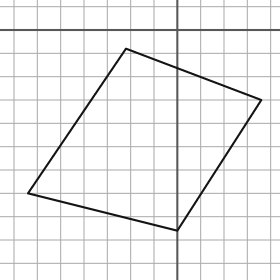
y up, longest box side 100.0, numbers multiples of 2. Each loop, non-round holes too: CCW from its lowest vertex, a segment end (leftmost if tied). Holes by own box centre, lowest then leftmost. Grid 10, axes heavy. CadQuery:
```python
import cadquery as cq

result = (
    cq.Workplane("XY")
    .moveTo(0.0, -86.0)
    .lineTo(36.0, -30.0)
    .lineTo(-22.0, -8.0)
    .lineTo(-64.0, -70.0)
    .close()
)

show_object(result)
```